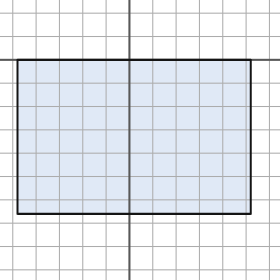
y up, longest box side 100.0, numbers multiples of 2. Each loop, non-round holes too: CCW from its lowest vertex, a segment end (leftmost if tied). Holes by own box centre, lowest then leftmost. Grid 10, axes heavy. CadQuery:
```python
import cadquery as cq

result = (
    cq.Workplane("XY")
    .moveTo(-48.0, -66.0)
    .lineTo(52.0, -66.0)
    .lineTo(52.0, 0.0)
    .lineTo(-48.0, 0.0)
    .close()
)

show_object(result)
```